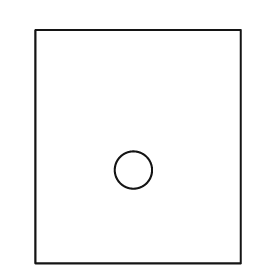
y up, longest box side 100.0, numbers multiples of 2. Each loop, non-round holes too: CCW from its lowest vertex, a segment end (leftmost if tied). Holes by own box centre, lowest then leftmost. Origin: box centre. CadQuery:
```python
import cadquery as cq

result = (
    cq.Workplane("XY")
    .moveTo(-44.0, -50.0)
    .lineTo(44.0, -50.0)
    .lineTo(44.0, 50.0)
    .lineTo(-44.0, 50.0)
    .close()
    .moveTo(-2.0, -10.0)
    .circle(8.0)
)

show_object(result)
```